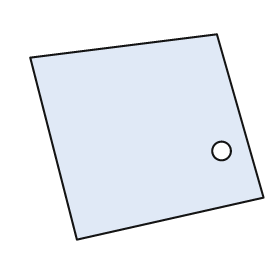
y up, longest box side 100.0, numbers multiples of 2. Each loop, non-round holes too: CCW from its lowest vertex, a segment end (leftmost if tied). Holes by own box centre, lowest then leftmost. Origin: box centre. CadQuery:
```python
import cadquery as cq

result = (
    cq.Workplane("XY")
    .moveTo(-30.0, -44.0)
    .lineTo(50.0, -26.0)
    .lineTo(30.0, 44.0)
    .lineTo(-50.0, 34.0)
    .close()
    .moveTo(32.0, -6.0)
    .circle(4.0)
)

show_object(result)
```